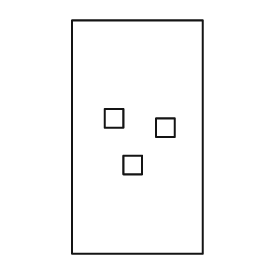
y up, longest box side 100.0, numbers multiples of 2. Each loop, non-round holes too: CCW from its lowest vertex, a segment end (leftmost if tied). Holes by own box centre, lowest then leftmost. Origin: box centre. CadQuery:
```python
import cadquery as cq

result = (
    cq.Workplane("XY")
    .moveTo(-28.0, -50.0)
    .lineTo(28.0, -50.0)
    .lineTo(28.0, 50.0)
    .lineTo(-28.0, 50.0)
    .close()
    .moveTo(-6.0, -16.0)
    .lineTo(2.0, -16.0)
    .lineTo(2.0, -8.0)
    .lineTo(-6.0, -8.0)
    .close()
    .moveTo(8.0, 0.0)
    .lineTo(16.0, 0.0)
    .lineTo(16.0, 8.0)
    .lineTo(8.0, 8.0)
    .close()
    .moveTo(-14.0, 4.0)
    .lineTo(-6.0, 4.0)
    .lineTo(-6.0, 12.0)
    .lineTo(-14.0, 12.0)
    .close()
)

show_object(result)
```